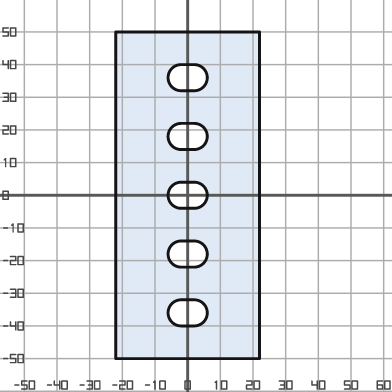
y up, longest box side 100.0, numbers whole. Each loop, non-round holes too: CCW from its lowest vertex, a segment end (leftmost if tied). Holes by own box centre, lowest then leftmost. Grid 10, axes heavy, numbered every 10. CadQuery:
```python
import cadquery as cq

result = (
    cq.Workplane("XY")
    .moveTo(-22.0, -50.0)
    .lineTo(22.0, -50.0)
    .lineTo(22.0, 50.0)
    .lineTo(-22.0, 50.0)
    .close()
    .moveTo(-2.0, -40.0)
    .lineTo(2.0, -40.0)
    .threePointArc((6.0, -36.0), (2.0, -32.0))
    .lineTo(-2.0, -32.0)
    .threePointArc((-6.0, -36.0), (-2.0, -40.0))
    .close()
    .moveTo(-2.0, -22.0)
    .lineTo(2.0, -22.0)
    .threePointArc((6.0, -18.0), (2.0, -14.0))
    .lineTo(-2.0, -14.0)
    .threePointArc((-6.0, -18.0), (-2.0, -22.0))
    .close()
    .moveTo(-2.0, -4.0)
    .lineTo(2.0, -4.0)
    .threePointArc((6.0, 0.0), (2.0, 4.0))
    .lineTo(-2.0, 4.0)
    .threePointArc((-6.0, 0.0), (-2.0, -4.0))
    .close()
    .moveTo(-2.0, 14.0)
    .lineTo(2.0, 14.0)
    .threePointArc((6.0, 18.0), (2.0, 22.0))
    .lineTo(-2.0, 22.0)
    .threePointArc((-6.0, 18.0), (-2.0, 14.0))
    .close()
    .moveTo(-2.0, 32.0)
    .lineTo(2.0, 32.0)
    .threePointArc((6.0, 36.0), (2.0, 40.0))
    .lineTo(-2.0, 40.0)
    .threePointArc((-6.0, 36.0), (-2.0, 32.0))
    .close()
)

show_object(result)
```